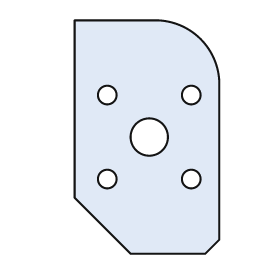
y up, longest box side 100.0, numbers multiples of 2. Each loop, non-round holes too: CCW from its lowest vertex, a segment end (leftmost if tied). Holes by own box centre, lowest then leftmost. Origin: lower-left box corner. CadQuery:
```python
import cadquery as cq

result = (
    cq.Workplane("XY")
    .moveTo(24.0, 0.0)
    .lineTo(56.0, 0.0)
    .lineTo(62.0, 6.0)
    .lineTo(62.0, 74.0)
    .threePointArc((54.0, 92.0), (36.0, 100.0))
    .lineTo(0.0, 100.0)
    .lineTo(0.0, 24.0)
    .close()
    .moveTo(14.0, 32.0)
    .circle(4.0)
    .moveTo(50.0, 32.0)
    .circle(4.0)
    .moveTo(32.0, 50.0)
    .circle(8.0)
    .moveTo(14.0, 68.0)
    .circle(4.0)
    .moveTo(50.0, 68.0)
    .circle(4.0)
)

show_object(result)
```